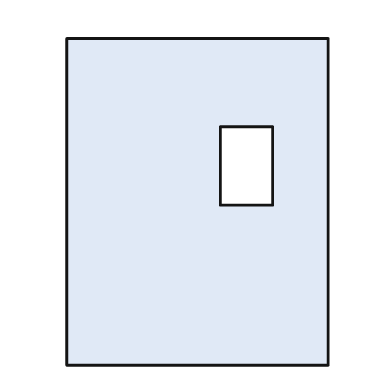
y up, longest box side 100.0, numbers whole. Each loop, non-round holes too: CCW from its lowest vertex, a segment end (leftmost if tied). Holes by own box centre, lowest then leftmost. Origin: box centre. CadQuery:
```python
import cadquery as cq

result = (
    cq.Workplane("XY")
    .moveTo(-40.0, -50.0)
    .lineTo(40.0, -50.0)
    .lineTo(40.0, 50.0)
    .lineTo(-40.0, 50.0)
    .close()
    .moveTo(7.0, -1.0)
    .lineTo(23.0, -1.0)
    .lineTo(23.0, 23.0)
    .lineTo(7.0, 23.0)
    .close()
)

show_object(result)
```